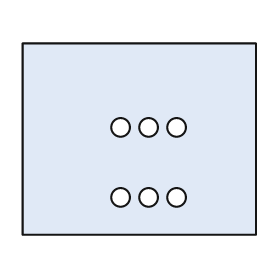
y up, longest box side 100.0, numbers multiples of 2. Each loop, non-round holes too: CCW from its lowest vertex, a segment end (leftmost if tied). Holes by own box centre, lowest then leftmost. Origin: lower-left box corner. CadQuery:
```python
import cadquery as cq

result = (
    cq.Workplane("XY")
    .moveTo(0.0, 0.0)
    .lineTo(100.0, 0.0)
    .lineTo(100.0, 82.0)
    .lineTo(0.0, 82.0)
    .close()
    .moveTo(42.0, 16.0)
    .circle(4.0)
    .moveTo(54.0, 16.0)
    .circle(4.0)
    .moveTo(66.0, 16.0)
    .circle(4.0)
    .moveTo(42.0, 46.0)
    .circle(4.0)
    .moveTo(54.0, 46.0)
    .circle(4.0)
    .moveTo(66.0, 46.0)
    .circle(4.0)
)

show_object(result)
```